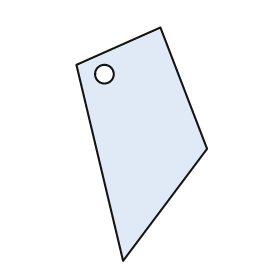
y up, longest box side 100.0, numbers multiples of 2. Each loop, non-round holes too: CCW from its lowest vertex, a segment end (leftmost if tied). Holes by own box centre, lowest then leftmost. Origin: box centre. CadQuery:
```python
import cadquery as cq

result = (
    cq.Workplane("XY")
    .moveTo(-8.0, -50.0)
    .lineTo(28.0, -2.0)
    .lineTo(8.0, 50.0)
    .lineTo(-28.0, 34.0)
    .close()
    .moveTo(-16.0, 30.0)
    .circle(4.0)
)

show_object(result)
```